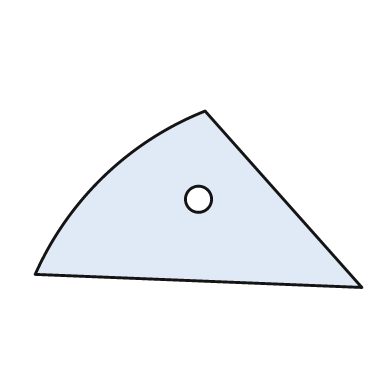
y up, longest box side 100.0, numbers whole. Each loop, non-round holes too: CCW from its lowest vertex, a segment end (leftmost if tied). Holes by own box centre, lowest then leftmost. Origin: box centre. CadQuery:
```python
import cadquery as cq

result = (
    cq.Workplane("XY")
    .moveTo(50.0, -27.0)
    .lineTo(2.0, 27.0)
    .threePointArc((-29.0, 7.0), (-50.0, -23.0))
    .close()
    .moveTo(0.0, 0.0)
    .circle(4.0)
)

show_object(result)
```